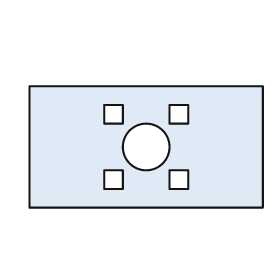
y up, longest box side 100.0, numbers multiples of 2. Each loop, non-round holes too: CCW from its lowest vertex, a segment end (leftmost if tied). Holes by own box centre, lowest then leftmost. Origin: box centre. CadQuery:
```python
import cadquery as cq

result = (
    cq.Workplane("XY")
    .moveTo(-50.0, -26.0)
    .lineTo(50.0, -26.0)
    .lineTo(50.0, 26.0)
    .lineTo(-50.0, 26.0)
    .close()
    .moveTo(-18.0, -18.0)
    .lineTo(-10.0, -18.0)
    .lineTo(-10.0, -10.0)
    .lineTo(-18.0, -10.0)
    .close()
    .moveTo(10.0, -18.0)
    .lineTo(18.0, -18.0)
    .lineTo(18.0, -10.0)
    .lineTo(10.0, -10.0)
    .close()
    .moveTo(0.0, 0.0)
    .circle(10.0)
    .moveTo(-18.0, 10.0)
    .lineTo(-10.0, 10.0)
    .lineTo(-10.0, 18.0)
    .lineTo(-18.0, 18.0)
    .close()
    .moveTo(10.0, 10.0)
    .lineTo(18.0, 10.0)
    .lineTo(18.0, 18.0)
    .lineTo(10.0, 18.0)
    .close()
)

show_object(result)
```